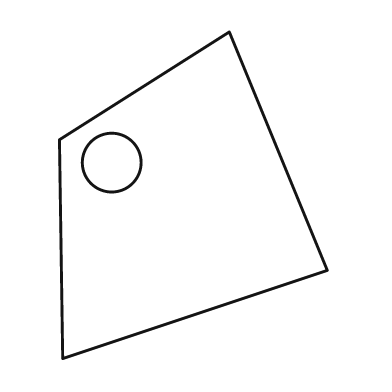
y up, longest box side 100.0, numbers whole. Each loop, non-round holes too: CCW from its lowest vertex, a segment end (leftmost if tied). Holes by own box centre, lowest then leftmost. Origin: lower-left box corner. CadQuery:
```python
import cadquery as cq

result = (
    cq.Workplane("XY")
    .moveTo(1.0, 0.0)
    .lineTo(82.0, 27.0)
    .lineTo(52.0, 100.0)
    .lineTo(0.0, 67.0)
    .close()
    .moveTo(16.0, 60.0)
    .circle(9.0)
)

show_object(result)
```